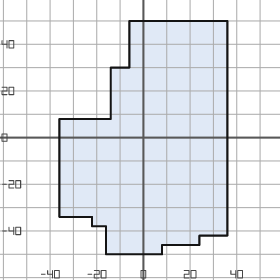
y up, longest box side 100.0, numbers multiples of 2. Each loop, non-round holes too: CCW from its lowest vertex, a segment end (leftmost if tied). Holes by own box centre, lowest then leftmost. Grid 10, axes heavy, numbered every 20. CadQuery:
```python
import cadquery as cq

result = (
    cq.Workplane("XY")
    .moveTo(-16.0, -50.0)
    .lineTo(8.0, -50.0)
    .lineTo(8.0, -46.0)
    .lineTo(24.0, -46.0)
    .lineTo(24.0, -42.0)
    .lineTo(36.0, -42.0)
    .lineTo(36.0, 50.0)
    .lineTo(-6.0, 50.0)
    .lineTo(-6.0, 30.0)
    .lineTo(-14.0, 30.0)
    .lineTo(-14.0, 8.0)
    .lineTo(-36.0, 8.0)
    .lineTo(-36.0, -34.0)
    .lineTo(-22.0, -34.0)
    .lineTo(-22.0, -38.0)
    .lineTo(-16.0, -38.0)
    .close()
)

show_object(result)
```